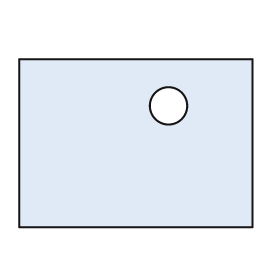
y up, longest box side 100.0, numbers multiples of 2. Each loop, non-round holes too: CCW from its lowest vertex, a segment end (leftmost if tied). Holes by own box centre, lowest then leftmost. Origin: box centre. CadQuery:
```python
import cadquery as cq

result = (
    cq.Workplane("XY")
    .moveTo(-50.0, -36.0)
    .lineTo(50.0, -36.0)
    .lineTo(50.0, 36.0)
    .lineTo(-50.0, 36.0)
    .close()
    .moveTo(14.0, 16.0)
    .circle(8.0)
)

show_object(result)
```